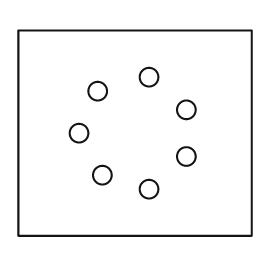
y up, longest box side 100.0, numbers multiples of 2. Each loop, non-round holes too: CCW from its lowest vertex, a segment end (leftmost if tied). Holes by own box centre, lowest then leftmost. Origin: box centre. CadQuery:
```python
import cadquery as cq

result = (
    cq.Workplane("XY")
    .moveTo(-50.0, -44.0)
    .lineTo(50.0, -44.0)
    .lineTo(50.0, 44.0)
    .lineTo(-50.0, 44.0)
    .close()
    .moveTo(6.0, -24.0)
    .circle(4.0)
    .moveTo(-14.0, -18.0)
    .circle(4.0)
    .moveTo(22.0, -10.0)
    .circle(4.0)
    .moveTo(-24.0, 0.0)
    .circle(4.0)
    .moveTo(22.0, 10.0)
    .circle(4.0)
    .moveTo(-16.0, 18.0)
    .circle(4.0)
    .moveTo(6.0, 24.0)
    .circle(4.0)
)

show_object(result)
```